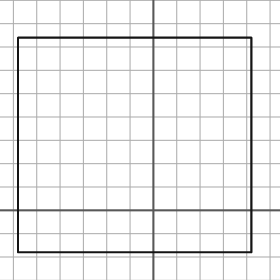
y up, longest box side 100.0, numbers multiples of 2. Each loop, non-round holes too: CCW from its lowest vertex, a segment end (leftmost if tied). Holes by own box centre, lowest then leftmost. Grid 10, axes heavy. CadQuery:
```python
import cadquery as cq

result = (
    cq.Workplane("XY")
    .moveTo(-58.0, -18.0)
    .lineTo(42.0, -18.0)
    .lineTo(42.0, 74.0)
    .lineTo(-58.0, 74.0)
    .close()
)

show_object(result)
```